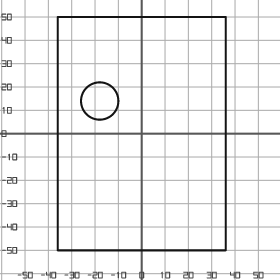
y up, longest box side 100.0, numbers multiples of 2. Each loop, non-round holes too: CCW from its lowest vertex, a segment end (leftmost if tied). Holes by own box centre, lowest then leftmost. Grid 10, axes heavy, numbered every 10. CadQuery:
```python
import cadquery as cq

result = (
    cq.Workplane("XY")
    .moveTo(-36.0, -50.0)
    .lineTo(36.0, -50.0)
    .lineTo(36.0, 50.0)
    .lineTo(-36.0, 50.0)
    .close()
    .moveTo(-18.0, 14.0)
    .circle(8.0)
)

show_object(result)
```